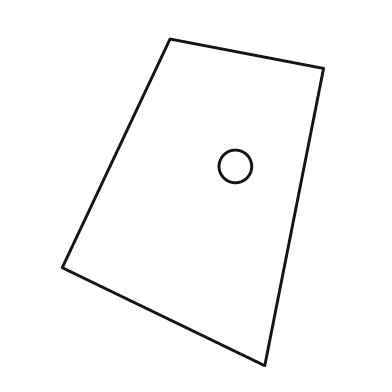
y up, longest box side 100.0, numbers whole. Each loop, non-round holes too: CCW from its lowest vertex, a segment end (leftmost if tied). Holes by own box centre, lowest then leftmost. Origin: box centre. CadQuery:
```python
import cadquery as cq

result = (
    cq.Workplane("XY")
    .moveTo(22.0, -50.0)
    .lineTo(40.0, 41.0)
    .lineTo(-7.0, 50.0)
    .lineTo(-40.0, -20.0)
    .close()
    .moveTo(13.0, 11.0)
    .circle(5.0)
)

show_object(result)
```